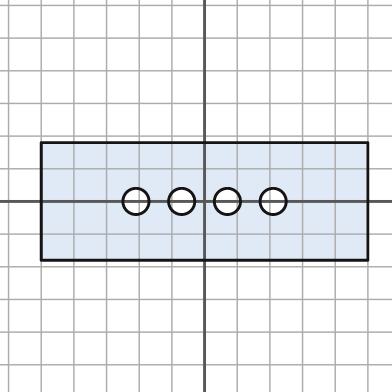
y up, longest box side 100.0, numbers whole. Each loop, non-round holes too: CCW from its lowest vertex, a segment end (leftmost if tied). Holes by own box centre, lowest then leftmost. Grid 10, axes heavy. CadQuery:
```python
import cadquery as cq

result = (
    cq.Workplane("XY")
    .moveTo(-50.0, -18.0)
    .lineTo(50.0, -18.0)
    .lineTo(50.0, 18.0)
    .lineTo(-50.0, 18.0)
    .close()
    .moveTo(-21.0, 0.0)
    .circle(4.0)
    .moveTo(-7.0, 0.0)
    .circle(4.0)
    .moveTo(7.0, 0.0)
    .circle(4.0)
    .moveTo(21.0, 0.0)
    .circle(4.0)
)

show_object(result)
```